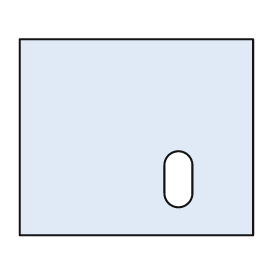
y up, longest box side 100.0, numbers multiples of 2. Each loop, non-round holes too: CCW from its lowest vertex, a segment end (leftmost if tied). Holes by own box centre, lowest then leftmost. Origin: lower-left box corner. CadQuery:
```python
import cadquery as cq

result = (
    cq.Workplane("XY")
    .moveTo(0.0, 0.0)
    .lineTo(100.0, 0.0)
    .lineTo(100.0, 84.0)
    .lineTo(0.0, 84.0)
    .close()
    .moveTo(62.0, 18.0)
    .threePointArc((68.0, 12.0), (74.0, 18.0))
    .lineTo(74.0, 30.0)
    .threePointArc((68.0, 36.0), (62.0, 30.0))
    .close()
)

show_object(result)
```